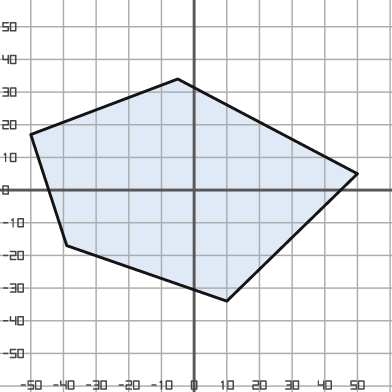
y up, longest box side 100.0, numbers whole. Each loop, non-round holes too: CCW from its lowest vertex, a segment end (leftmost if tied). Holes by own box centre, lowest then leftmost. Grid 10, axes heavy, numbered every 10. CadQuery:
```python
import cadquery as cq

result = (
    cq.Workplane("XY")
    .moveTo(10.0, -34.0)
    .lineTo(50.0, 5.0)
    .lineTo(-5.0, 34.0)
    .lineTo(-50.0, 17.0)
    .lineTo(-39.0, -17.0)
    .close()
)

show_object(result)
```